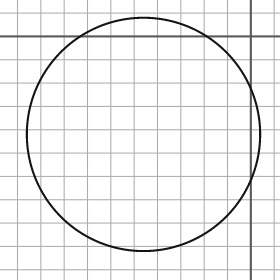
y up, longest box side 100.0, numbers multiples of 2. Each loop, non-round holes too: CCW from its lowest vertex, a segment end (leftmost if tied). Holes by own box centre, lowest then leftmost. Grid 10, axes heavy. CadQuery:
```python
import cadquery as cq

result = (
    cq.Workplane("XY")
    .moveTo(-46.0, -42.0)
    .circle(50.0)
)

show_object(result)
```